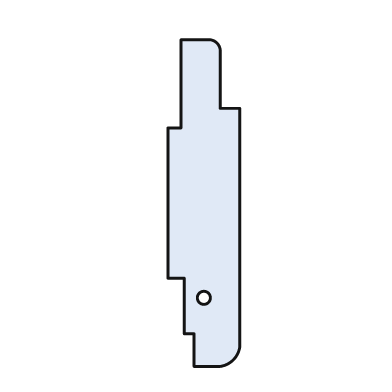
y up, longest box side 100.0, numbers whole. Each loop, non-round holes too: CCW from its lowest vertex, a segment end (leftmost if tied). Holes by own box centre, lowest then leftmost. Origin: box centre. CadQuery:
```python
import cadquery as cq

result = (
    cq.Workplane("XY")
    .moveTo(-3.0, -50.0)
    .lineTo(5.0, -50.0)
    .threePointArc((9.0, -48.0), (11.0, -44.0))
    .lineTo(11.0, 29.0)
    .lineTo(5.0, 29.0)
    .lineTo(5.0, 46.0)
    .threePointArc((4.0, 49.0), (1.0, 50.0))
    .lineTo(-7.0, 50.0)
    .lineTo(-7.0, 23.0)
    .lineTo(-11.0, 23.0)
    .lineTo(-11.0, -23.0)
    .lineTo(-6.0, -23.0)
    .lineTo(-6.0, -40.0)
    .lineTo(-3.0, -40.0)
    .close()
    .moveTo(0.0, -29.0)
    .circle(2.0)
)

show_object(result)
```